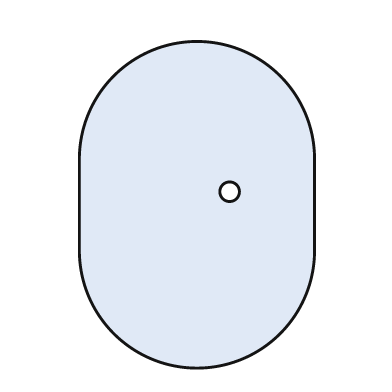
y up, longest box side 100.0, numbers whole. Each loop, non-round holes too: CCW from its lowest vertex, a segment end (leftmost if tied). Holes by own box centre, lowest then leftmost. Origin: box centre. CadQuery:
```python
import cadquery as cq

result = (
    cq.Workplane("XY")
    .moveTo(-36.0, -14.0)
    .threePointArc((0.0, -50.0), (36.0, -14.0))
    .lineTo(36.0, 14.0)
    .threePointArc((0.0, 50.0), (-36.0, 14.0))
    .close()
    .moveTo(10.0, 4.0)
    .circle(3.0)
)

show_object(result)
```